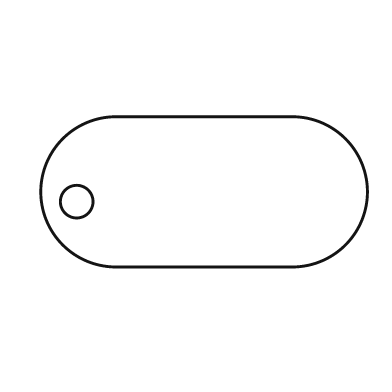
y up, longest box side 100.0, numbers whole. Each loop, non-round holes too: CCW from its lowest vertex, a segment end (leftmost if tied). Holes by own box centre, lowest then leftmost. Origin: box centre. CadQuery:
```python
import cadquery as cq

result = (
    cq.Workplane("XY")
    .moveTo(-27.0, -23.0)
    .lineTo(27.0, -23.0)
    .threePointArc((50.0, 0.0), (27.0, 23.0))
    .lineTo(-27.0, 23.0)
    .threePointArc((-50.0, 0.0), (-27.0, -23.0))
    .close()
    .moveTo(-39.0, -3.0)
    .circle(5.0)
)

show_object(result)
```